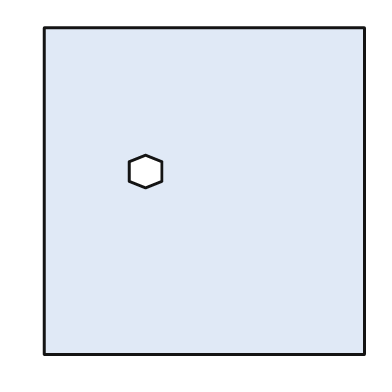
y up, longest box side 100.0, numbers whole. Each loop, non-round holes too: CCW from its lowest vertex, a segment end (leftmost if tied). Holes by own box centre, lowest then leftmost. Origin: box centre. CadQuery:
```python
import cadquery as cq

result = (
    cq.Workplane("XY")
    .moveTo(-49.0, -50.0)
    .lineTo(49.0, -50.0)
    .lineTo(49.0, 50.0)
    .lineTo(-49.0, 50.0)
    .close()
    .moveTo(-18.0, 1.0)
    .lineTo(-13.0, 3.0)
    .lineTo(-13.0, 9.0)
    .lineTo(-18.0, 11.0)
    .lineTo(-23.0, 9.0)
    .lineTo(-23.0, 3.0)
    .close()
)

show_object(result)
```